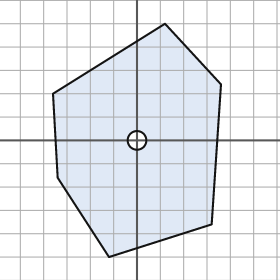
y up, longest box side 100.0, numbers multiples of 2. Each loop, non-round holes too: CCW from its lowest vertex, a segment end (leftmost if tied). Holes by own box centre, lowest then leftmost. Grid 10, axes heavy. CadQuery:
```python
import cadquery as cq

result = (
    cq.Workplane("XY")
    .moveTo(-12.0, -50.0)
    .lineTo(32.0, -36.0)
    .lineTo(36.0, 24.0)
    .lineTo(12.0, 50.0)
    .lineTo(-36.0, 20.0)
    .lineTo(-34.0, -16.0)
    .close()
    .moveTo(0.0, 0.0)
    .circle(4.0)
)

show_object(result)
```